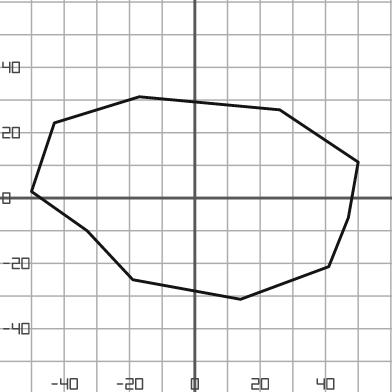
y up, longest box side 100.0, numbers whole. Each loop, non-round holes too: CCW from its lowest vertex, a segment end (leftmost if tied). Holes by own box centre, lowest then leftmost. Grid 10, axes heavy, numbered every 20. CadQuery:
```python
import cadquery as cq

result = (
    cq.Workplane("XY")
    .moveTo(14.0, -31.0)
    .lineTo(41.0, -21.0)
    .lineTo(47.0, -6.0)
    .lineTo(50.0, 11.0)
    .lineTo(26.0, 27.0)
    .lineTo(-17.0, 31.0)
    .lineTo(-43.0, 23.0)
    .lineTo(-50.0, 2.0)
    .lineTo(-33.0, -10.0)
    .lineTo(-19.0, -25.0)
    .close()
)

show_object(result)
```